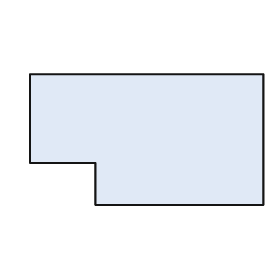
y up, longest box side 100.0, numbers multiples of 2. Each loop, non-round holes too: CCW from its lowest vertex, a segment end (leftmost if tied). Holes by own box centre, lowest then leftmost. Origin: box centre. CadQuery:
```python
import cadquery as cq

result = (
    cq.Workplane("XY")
    .moveTo(-22.0, -28.0)
    .lineTo(50.0, -28.0)
    .lineTo(50.0, 28.0)
    .lineTo(-50.0, 28.0)
    .lineTo(-50.0, -10.0)
    .lineTo(-22.0, -10.0)
    .close()
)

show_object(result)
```